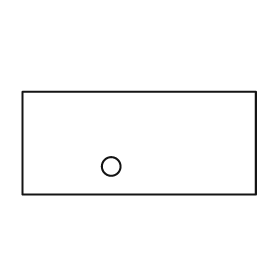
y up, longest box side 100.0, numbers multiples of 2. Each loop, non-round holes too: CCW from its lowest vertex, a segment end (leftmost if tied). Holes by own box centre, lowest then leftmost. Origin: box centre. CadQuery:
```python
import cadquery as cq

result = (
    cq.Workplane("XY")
    .moveTo(-50.0, -22.0)
    .lineTo(50.0, -22.0)
    .lineTo(50.0, 22.0)
    .lineTo(-50.0, 22.0)
    .close()
    .moveTo(-12.0, -10.0)
    .circle(4.0)
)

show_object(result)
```